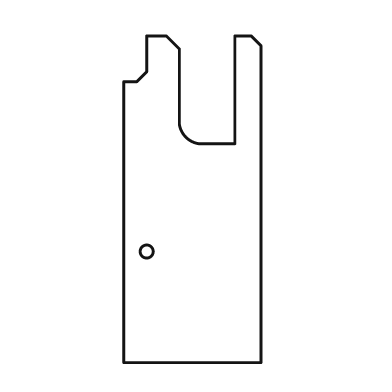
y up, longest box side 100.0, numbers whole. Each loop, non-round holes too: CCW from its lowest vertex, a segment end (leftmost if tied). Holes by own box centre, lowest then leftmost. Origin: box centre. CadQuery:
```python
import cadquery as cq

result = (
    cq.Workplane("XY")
    .moveTo(-21.0, -50.0)
    .lineTo(21.0, -50.0)
    .lineTo(21.0, 47.0)
    .lineTo(18.0, 50.0)
    .lineTo(13.0, 50.0)
    .lineTo(13.0, 17.0)
    .lineTo(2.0, 17.0)
    .threePointArc((-2.0, 19.0), (-4.0, 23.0))
    .lineTo(-4.0, 46.0)
    .lineTo(-8.0, 50.0)
    .lineTo(-14.0, 50.0)
    .lineTo(-14.0, 39.0)
    .lineTo(-17.0, 36.0)
    .lineTo(-21.0, 36.0)
    .close()
    .moveTo(-14.0, -16.0)
    .circle(2.0)
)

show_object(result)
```